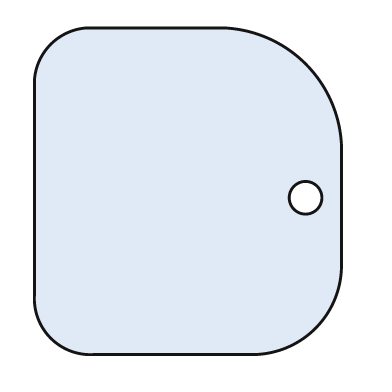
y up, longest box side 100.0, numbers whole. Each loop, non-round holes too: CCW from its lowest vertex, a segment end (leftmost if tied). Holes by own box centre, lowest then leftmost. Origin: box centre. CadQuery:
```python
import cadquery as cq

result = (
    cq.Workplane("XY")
    .moveTo(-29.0, -50.0)
    .lineTo(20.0, -50.0)
    .threePointArc((39.0, -42.0), (47.0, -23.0))
    .lineTo(47.0, 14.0)
    .threePointArc((36.0, 39.0), (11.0, 50.0))
    .lineTo(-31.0, 50.0)
    .threePointArc((-42.0, 45.0), (-47.0, 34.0))
    .lineTo(-47.0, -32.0)
    .threePointArc((-42.0, -45.0), (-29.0, -50.0))
    .close()
    .moveTo(36.0, -2.0)
    .circle(5.0)
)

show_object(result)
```